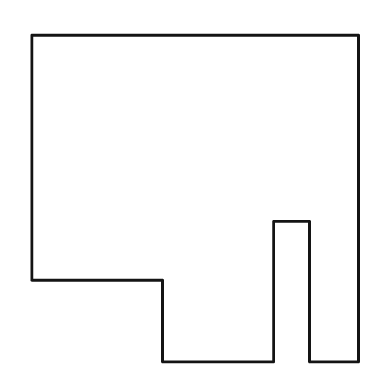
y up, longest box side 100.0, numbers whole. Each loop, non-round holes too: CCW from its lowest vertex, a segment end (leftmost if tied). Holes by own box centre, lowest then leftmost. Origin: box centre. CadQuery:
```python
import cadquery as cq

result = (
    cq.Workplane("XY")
    .moveTo(-10.0, -50.0)
    .lineTo(24.0, -50.0)
    .lineTo(24.0, -7.0)
    .lineTo(35.0, -7.0)
    .lineTo(35.0, -50.0)
    .lineTo(50.0, -50.0)
    .lineTo(50.0, 50.0)
    .lineTo(-50.0, 50.0)
    .lineTo(-50.0, -25.0)
    .lineTo(-10.0, -25.0)
    .close()
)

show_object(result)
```